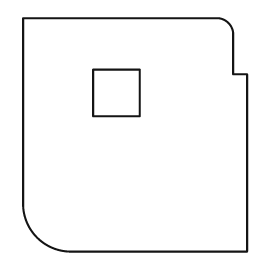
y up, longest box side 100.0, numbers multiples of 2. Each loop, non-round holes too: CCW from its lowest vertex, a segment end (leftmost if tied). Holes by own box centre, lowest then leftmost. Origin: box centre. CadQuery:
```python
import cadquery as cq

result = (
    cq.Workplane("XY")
    .moveTo(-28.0, -50.0)
    .lineTo(48.0, -50.0)
    .lineTo(48.0, 26.0)
    .lineTo(42.0, 26.0)
    .lineTo(42.0, 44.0)
    .threePointArc((40.0, 48.0), (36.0, 50.0))
    .lineTo(-48.0, 50.0)
    .lineTo(-48.0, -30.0)
    .threePointArc((-42.0, -44.0), (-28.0, -50.0))
    .close()
    .moveTo(-18.0, 8.0)
    .lineTo(2.0, 8.0)
    .lineTo(2.0, 28.0)
    .lineTo(-18.0, 28.0)
    .close()
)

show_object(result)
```